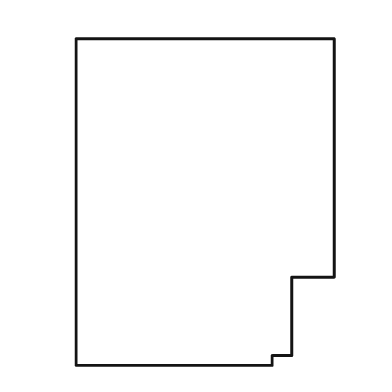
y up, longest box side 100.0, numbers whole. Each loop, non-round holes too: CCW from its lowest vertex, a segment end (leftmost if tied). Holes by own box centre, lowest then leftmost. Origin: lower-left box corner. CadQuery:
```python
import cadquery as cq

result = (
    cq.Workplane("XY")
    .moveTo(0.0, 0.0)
    .lineTo(60.0, 0.0)
    .lineTo(60.0, 3.0)
    .lineTo(66.0, 3.0)
    .lineTo(66.0, 27.0)
    .lineTo(79.0, 27.0)
    .lineTo(79.0, 100.0)
    .lineTo(0.0, 100.0)
    .close()
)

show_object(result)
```